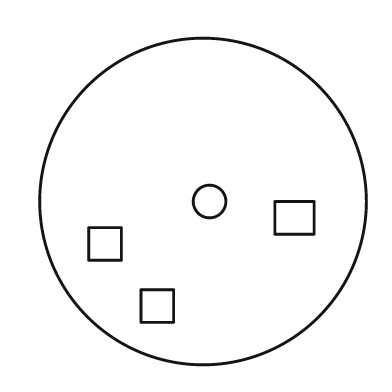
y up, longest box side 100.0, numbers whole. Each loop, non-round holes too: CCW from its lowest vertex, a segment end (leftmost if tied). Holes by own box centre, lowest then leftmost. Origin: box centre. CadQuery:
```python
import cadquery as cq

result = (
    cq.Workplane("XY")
    .moveTo(0.0, 0.0)
    .circle(50.0)
    .moveTo(-19.0, -37.0)
    .lineTo(-9.0, -37.0)
    .lineTo(-9.0, -27.0)
    .lineTo(-19.0, -27.0)
    .close()
    .moveTo(-35.0, -18.0)
    .lineTo(-25.0, -18.0)
    .lineTo(-25.0, -8.0)
    .lineTo(-35.0, -8.0)
    .close()
    .moveTo(22.0, -10.0)
    .lineTo(34.0, -10.0)
    .lineTo(34.0, 0.0)
    .lineTo(22.0, 0.0)
    .close()
    .moveTo(2.0, 0.0)
    .circle(5.0)
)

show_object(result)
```